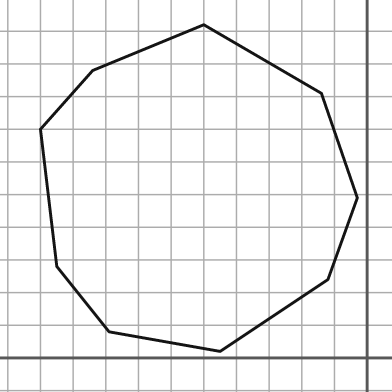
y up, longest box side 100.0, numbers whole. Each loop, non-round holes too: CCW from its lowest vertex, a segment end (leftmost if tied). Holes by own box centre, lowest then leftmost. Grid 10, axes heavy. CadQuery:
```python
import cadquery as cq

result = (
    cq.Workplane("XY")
    .moveTo(-45.0, 2.0)
    .lineTo(-12.0, 24.0)
    .lineTo(-3.0, 49.0)
    .lineTo(-14.0, 81.0)
    .lineTo(-50.0, 102.0)
    .lineTo(-84.0, 88.0)
    .lineTo(-100.0, 70.0)
    .lineTo(-95.0, 28.0)
    .lineTo(-79.0, 8.0)
    .close()
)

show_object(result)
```